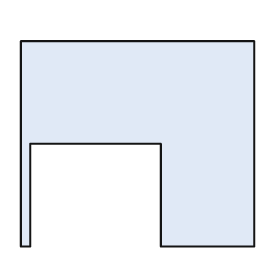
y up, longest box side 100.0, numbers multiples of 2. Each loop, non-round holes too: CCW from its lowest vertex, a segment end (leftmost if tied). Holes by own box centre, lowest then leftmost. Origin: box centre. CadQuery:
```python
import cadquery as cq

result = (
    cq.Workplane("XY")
    .moveTo(-50.0, -44.0)
    .lineTo(-46.0, -44.0)
    .lineTo(-46.0, 0.0)
    .lineTo(10.0, 0.0)
    .lineTo(10.0, -44.0)
    .lineTo(50.0, -44.0)
    .lineTo(50.0, 44.0)
    .lineTo(-50.0, 44.0)
    .close()
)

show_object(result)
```